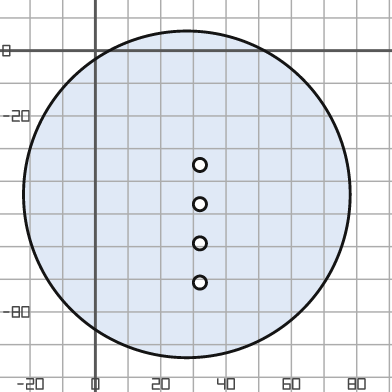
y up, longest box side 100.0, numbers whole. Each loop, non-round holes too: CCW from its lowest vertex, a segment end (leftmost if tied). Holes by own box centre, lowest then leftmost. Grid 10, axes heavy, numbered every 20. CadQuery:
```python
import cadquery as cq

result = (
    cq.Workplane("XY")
    .moveTo(28.0, -44.0)
    .circle(50.0)
    .moveTo(32.0, -71.0)
    .circle(2.0)
    .moveTo(32.0, -59.0)
    .circle(2.0)
    .moveTo(32.0, -47.0)
    .circle(2.0)
    .moveTo(32.0, -35.0)
    .circle(2.0)
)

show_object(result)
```